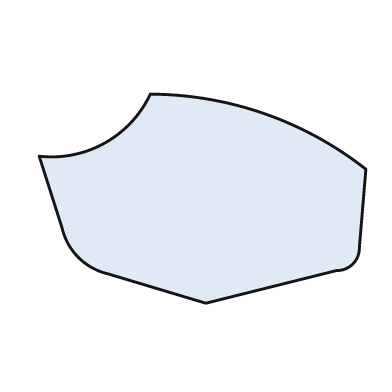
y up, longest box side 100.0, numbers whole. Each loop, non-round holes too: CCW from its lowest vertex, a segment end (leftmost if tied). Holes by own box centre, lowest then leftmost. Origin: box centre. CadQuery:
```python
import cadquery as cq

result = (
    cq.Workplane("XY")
    .moveTo(1.0, -32.0)
    .lineTo(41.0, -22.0)
    .threePointArc((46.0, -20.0), (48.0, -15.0))
    .lineTo(50.0, 9.0)
    .threePointArc((19.0, 26.0), (-16.0, 32.0))
    .threePointArc((-30.0, 17.0), (-50.0, 13.0))
    .lineTo(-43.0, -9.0)
    .threePointArc((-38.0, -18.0), (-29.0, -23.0))
    .close()
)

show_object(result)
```